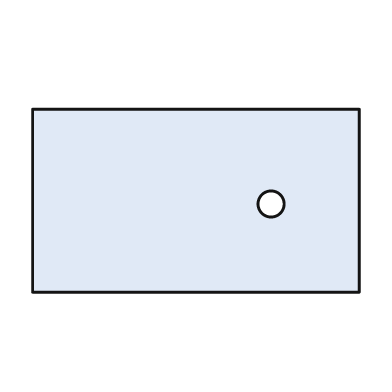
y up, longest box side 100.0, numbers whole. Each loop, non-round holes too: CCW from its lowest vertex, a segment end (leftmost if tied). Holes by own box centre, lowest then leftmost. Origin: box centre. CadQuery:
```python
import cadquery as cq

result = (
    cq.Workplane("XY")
    .moveTo(-50.0, -28.0)
    .lineTo(50.0, -28.0)
    .lineTo(50.0, 28.0)
    .lineTo(-50.0, 28.0)
    .close()
    .moveTo(23.0, -1.0)
    .circle(4.0)
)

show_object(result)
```